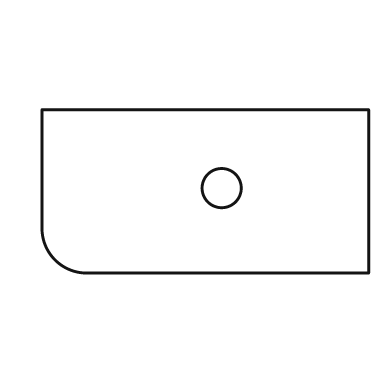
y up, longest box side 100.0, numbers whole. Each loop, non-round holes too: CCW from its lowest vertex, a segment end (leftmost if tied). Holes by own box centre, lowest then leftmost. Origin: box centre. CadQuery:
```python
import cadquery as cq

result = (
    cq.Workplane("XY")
    .moveTo(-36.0, -25.0)
    .lineTo(50.0, -25.0)
    .lineTo(50.0, 25.0)
    .lineTo(-50.0, 25.0)
    .lineTo(-50.0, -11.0)
    .threePointArc((-46.0, -21.0), (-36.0, -25.0))
    .close()
    .moveTo(5.0, 1.0)
    .circle(6.0)
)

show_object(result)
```